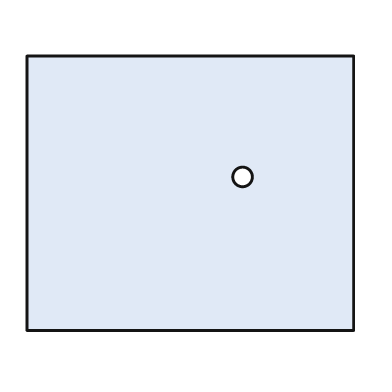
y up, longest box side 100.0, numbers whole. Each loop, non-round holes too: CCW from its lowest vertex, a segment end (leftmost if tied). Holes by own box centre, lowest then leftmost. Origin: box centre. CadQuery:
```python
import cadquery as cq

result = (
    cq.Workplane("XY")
    .moveTo(-50.0, -42.0)
    .lineTo(50.0, -42.0)
    .lineTo(50.0, 42.0)
    .lineTo(-50.0, 42.0)
    .close()
    .moveTo(16.0, 5.0)
    .circle(3.0)
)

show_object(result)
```